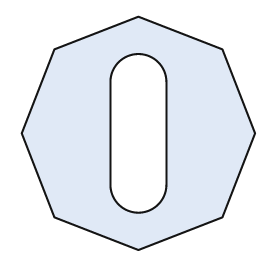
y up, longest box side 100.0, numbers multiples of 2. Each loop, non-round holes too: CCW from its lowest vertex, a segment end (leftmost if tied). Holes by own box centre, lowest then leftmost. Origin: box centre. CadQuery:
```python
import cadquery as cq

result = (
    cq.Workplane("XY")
    .moveTo(0.0, -50.0)
    .lineTo(36.0, -36.0)
    .lineTo(50.0, 0.0)
    .lineTo(36.0, 36.0)
    .lineTo(0.0, 50.0)
    .lineTo(-36.0, 36.0)
    .lineTo(-50.0, 0.0)
    .lineTo(-36.0, -36.0)
    .close()
    .moveTo(-12.0, -22.0)
    .threePointArc((0.0, -34.0), (12.0, -22.0))
    .lineTo(12.0, 22.0)
    .threePointArc((0.0, 34.0), (-12.0, 22.0))
    .close()
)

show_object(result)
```